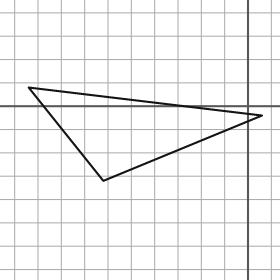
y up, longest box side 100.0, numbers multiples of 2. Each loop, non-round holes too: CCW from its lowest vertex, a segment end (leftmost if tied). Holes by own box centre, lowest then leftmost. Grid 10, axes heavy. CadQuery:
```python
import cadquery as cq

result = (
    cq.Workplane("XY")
    .moveTo(-62.0, -32.0)
    .lineTo(6.0, -4.0)
    .lineTo(-94.0, 8.0)
    .close()
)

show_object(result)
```